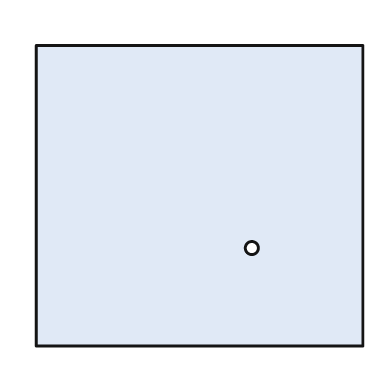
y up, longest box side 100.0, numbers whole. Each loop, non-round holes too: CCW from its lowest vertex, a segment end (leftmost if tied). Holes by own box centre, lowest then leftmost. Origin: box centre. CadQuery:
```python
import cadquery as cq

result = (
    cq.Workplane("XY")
    .moveTo(-50.0, -46.0)
    .lineTo(50.0, -46.0)
    .lineTo(50.0, 46.0)
    .lineTo(-50.0, 46.0)
    .close()
    .moveTo(16.0, -16.0)
    .circle(2.0)
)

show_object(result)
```